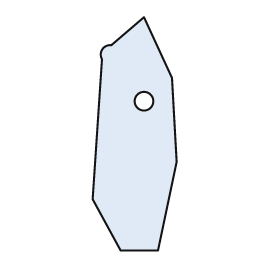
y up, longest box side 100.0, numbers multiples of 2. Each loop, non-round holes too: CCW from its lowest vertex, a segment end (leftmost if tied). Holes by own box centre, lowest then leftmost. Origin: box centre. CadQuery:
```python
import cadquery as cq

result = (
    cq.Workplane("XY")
    .moveTo(-6.0, -50.0)
    .lineTo(10.0, -50.0)
    .lineTo(18.0, -12.0)
    .lineTo(16.0, 24.0)
    .lineTo(4.0, 50.0)
    .lineTo(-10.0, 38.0)
    .threePointArc((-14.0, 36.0), (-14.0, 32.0))
    .lineTo(-18.0, -28.0)
    .close()
    .moveTo(4.0, 14.0)
    .circle(4.0)
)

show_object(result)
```